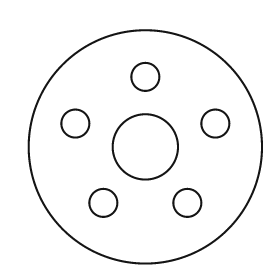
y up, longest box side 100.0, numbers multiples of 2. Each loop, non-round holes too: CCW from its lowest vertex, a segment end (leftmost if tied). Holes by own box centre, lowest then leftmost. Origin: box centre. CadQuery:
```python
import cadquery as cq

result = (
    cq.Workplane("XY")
    .moveTo(0.0, 0.0)
    .circle(50.0)
    .moveTo(-18.0, -24.0)
    .circle(6.0)
    .moveTo(18.0, -24.0)
    .circle(6.0)
    .moveTo(0.0, 0.0)
    .circle(14.0)
    .moveTo(-30.0, 10.0)
    .circle(6.0)
    .moveTo(30.0, 10.0)
    .circle(6.0)
    .moveTo(0.0, 30.0)
    .circle(6.0)
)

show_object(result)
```